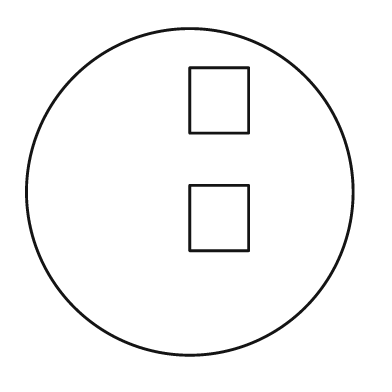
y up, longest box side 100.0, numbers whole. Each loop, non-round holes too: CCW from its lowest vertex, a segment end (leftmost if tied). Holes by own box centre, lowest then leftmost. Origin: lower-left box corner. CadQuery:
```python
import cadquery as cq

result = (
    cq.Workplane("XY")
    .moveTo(50.0, 50.0)
    .circle(50.0)
    .moveTo(50.0, 32.0)
    .lineTo(68.0, 32.0)
    .lineTo(68.0, 52.0)
    .lineTo(50.0, 52.0)
    .close()
    .moveTo(50.0, 68.0)
    .lineTo(68.0, 68.0)
    .lineTo(68.0, 88.0)
    .lineTo(50.0, 88.0)
    .close()
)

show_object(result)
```